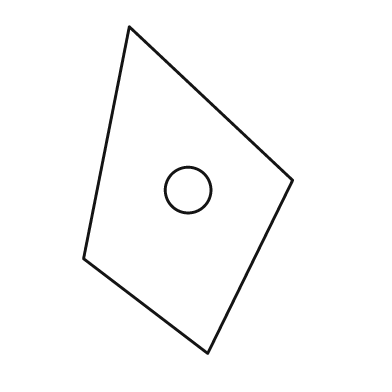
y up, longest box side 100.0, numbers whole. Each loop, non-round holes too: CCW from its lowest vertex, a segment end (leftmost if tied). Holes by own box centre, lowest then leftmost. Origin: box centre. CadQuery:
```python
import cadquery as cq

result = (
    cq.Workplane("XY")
    .moveTo(6.0, -50.0)
    .lineTo(32.0, 3.0)
    .lineTo(-18.0, 50.0)
    .lineTo(-32.0, -21.0)
    .close()
    .moveTo(0.0, 0.0)
    .circle(7.0)
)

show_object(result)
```